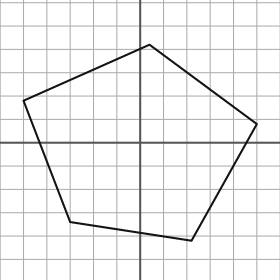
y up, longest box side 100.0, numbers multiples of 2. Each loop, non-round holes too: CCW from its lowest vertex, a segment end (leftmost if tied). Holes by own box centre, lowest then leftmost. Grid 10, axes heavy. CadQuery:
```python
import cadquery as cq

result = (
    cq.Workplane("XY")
    .moveTo(22.0, -42.0)
    .lineTo(50.0, 8.0)
    .lineTo(4.0, 42.0)
    .lineTo(-50.0, 18.0)
    .lineTo(-30.0, -34.0)
    .close()
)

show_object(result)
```